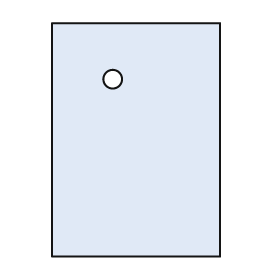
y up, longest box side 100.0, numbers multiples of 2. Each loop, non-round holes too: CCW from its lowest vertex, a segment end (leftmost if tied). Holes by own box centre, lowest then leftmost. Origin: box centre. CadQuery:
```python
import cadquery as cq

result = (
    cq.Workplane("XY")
    .moveTo(-36.0, -50.0)
    .lineTo(36.0, -50.0)
    .lineTo(36.0, 50.0)
    .lineTo(-36.0, 50.0)
    .close()
    .moveTo(-10.0, 26.0)
    .circle(4.0)
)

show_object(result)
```